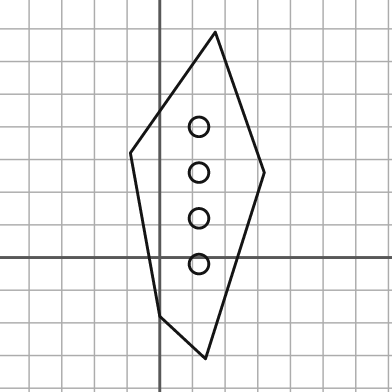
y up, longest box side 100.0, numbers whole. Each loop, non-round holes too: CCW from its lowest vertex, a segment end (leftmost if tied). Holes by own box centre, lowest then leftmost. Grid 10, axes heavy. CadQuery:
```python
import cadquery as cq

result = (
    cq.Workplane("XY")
    .moveTo(14.0, -31.0)
    .lineTo(32.0, 26.0)
    .lineTo(17.0, 69.0)
    .lineTo(-9.0, 32.0)
    .lineTo(0.0, -18.0)
    .close()
    .moveTo(12.0, -2.0)
    .circle(3.0)
    .moveTo(12.0, 12.0)
    .circle(3.0)
    .moveTo(12.0, 26.0)
    .circle(3.0)
    .moveTo(12.0, 40.0)
    .circle(3.0)
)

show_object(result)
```